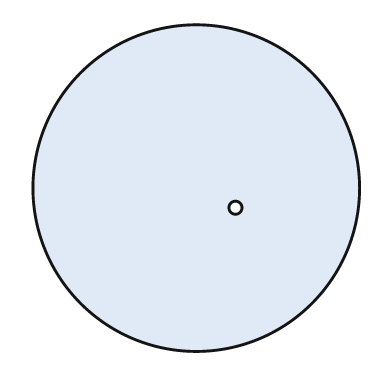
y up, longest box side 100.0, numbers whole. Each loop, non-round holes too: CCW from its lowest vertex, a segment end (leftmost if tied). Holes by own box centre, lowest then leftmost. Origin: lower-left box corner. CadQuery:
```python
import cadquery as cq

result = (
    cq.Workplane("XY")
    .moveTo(50.0, 50.0)
    .circle(50.0)
    .moveTo(62.0, 44.0)
    .circle(2.0)
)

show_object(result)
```